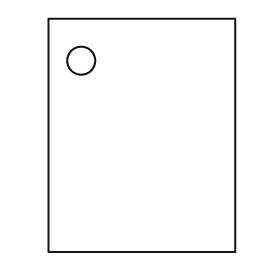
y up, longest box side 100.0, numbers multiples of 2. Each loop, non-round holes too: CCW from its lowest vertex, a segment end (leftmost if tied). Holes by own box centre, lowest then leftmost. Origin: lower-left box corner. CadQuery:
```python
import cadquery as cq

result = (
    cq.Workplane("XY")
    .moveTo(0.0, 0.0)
    .lineTo(80.0, 0.0)
    .lineTo(80.0, 100.0)
    .lineTo(0.0, 100.0)
    .close()
    .moveTo(14.0, 82.0)
    .circle(6.0)
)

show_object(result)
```